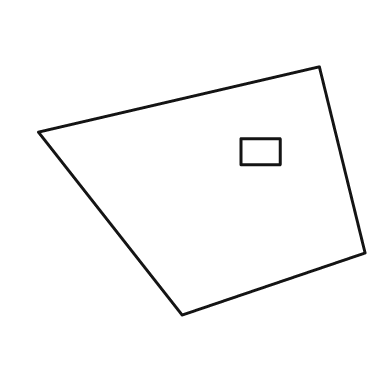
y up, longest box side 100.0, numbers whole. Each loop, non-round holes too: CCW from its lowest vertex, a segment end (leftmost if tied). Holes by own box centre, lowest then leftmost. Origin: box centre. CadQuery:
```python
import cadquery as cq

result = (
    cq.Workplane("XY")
    .moveTo(-6.0, -38.0)
    .lineTo(50.0, -19.0)
    .lineTo(36.0, 38.0)
    .lineTo(-50.0, 18.0)
    .close()
    .moveTo(12.0, 8.0)
    .lineTo(24.0, 8.0)
    .lineTo(24.0, 16.0)
    .lineTo(12.0, 16.0)
    .close()
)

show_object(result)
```